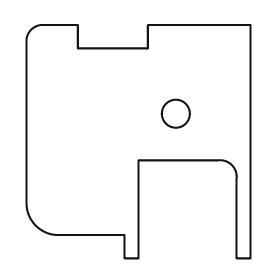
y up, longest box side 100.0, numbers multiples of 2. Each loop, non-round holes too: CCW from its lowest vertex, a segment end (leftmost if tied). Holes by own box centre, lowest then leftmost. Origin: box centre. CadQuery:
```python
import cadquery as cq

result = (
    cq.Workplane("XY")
    .moveTo(-6.0, -50.0)
    .lineTo(0.0, -50.0)
    .lineTo(0.0, -8.0)
    .lineTo(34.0, -8.0)
    .threePointArc((40.0, -10.0), (42.0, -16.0))
    .lineTo(42.0, -50.0)
    .lineTo(48.0, -50.0)
    .lineTo(48.0, 50.0)
    .lineTo(4.0, 50.0)
    .lineTo(4.0, 40.0)
    .lineTo(-26.0, 40.0)
    .lineTo(-26.0, 50.0)
    .lineTo(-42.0, 50.0)
    .threePointArc((-46.0, 48.0), (-48.0, 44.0))
    .lineTo(-48.0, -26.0)
    .threePointArc((-44.0, -36.0), (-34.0, -40.0))
    .lineTo(-6.0, -40.0)
    .close()
    .moveTo(16.0, 12.0)
    .circle(6.0)
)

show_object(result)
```